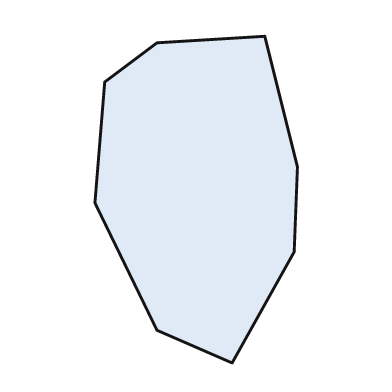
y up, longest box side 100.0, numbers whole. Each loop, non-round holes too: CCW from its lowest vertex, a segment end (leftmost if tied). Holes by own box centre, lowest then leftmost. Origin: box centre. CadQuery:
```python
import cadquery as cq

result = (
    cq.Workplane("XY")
    .moveTo(11.0, -50.0)
    .lineTo(30.0, -16.0)
    .lineTo(31.0, 10.0)
    .lineTo(21.0, 50.0)
    .lineTo(-12.0, 48.0)
    .lineTo(-28.0, 36.0)
    .lineTo(-31.0, -1.0)
    .lineTo(-12.0, -40.0)
    .close()
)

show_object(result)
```